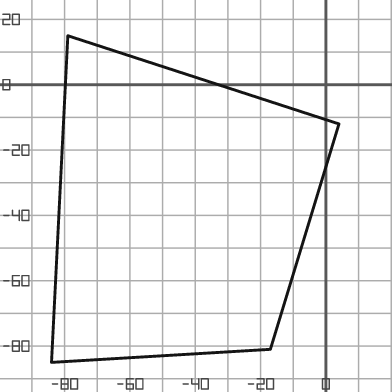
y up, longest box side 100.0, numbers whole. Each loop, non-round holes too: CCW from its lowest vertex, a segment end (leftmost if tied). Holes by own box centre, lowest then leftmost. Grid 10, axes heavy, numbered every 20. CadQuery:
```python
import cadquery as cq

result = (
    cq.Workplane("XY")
    .moveTo(-84.0, -85.0)
    .lineTo(-17.0, -81.0)
    .lineTo(4.0, -12.0)
    .lineTo(-79.0, 15.0)
    .close()
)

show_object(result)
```